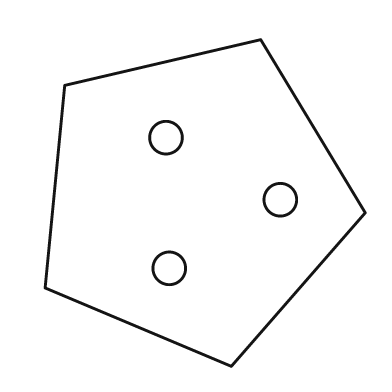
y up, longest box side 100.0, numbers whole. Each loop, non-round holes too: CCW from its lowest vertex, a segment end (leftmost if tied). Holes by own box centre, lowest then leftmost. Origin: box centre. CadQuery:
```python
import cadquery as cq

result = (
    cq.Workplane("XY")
    .moveTo(8.0, -50.0)
    .lineTo(49.0, -3.0)
    .lineTo(17.0, 50.0)
    .lineTo(-43.0, 36.0)
    .lineTo(-49.0, -26.0)
    .close()
    .moveTo(-11.0, -20.0)
    .circle(5.0)
    .moveTo(23.0, 1.0)
    .circle(5.0)
    .moveTo(-12.0, 20.0)
    .circle(5.0)
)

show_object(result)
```